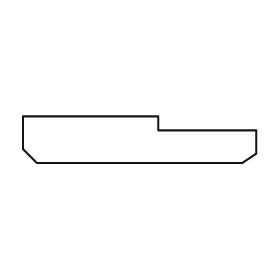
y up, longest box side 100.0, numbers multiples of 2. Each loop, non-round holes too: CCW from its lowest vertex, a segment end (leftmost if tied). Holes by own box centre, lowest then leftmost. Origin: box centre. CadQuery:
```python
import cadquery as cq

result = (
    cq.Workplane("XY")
    .moveTo(-44.0, -10.0)
    .lineTo(44.0, -10.0)
    .lineTo(50.0, -6.0)
    .lineTo(50.0, 4.0)
    .lineTo(8.0, 4.0)
    .lineTo(8.0, 10.0)
    .lineTo(-50.0, 10.0)
    .lineTo(-50.0, -4.0)
    .close()
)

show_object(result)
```